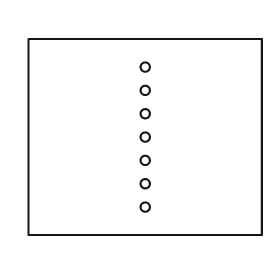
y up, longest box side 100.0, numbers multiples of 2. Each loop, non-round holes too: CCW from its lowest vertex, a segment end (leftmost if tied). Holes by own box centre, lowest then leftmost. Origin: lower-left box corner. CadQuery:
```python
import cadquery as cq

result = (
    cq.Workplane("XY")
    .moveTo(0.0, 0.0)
    .lineTo(100.0, 0.0)
    .lineTo(100.0, 84.0)
    .lineTo(0.0, 84.0)
    .close()
    .moveTo(50.0, 12.0)
    .circle(2.0)
    .moveTo(50.0, 22.0)
    .circle(2.0)
    .moveTo(50.0, 32.0)
    .circle(2.0)
    .moveTo(50.0, 42.0)
    .circle(2.0)
    .moveTo(50.0, 52.0)
    .circle(2.0)
    .moveTo(50.0, 62.0)
    .circle(2.0)
    .moveTo(50.0, 72.0)
    .circle(2.0)
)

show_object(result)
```